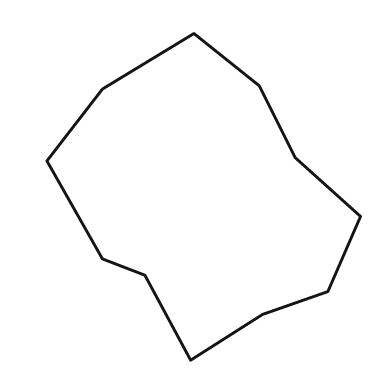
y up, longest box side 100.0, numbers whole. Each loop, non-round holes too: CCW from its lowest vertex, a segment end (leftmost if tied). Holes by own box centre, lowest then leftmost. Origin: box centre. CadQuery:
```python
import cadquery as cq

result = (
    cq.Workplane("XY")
    .moveTo(-4.0, -50.0)
    .lineTo(18.0, -36.0)
    .lineTo(38.0, -29.0)
    .lineTo(48.0, -6.0)
    .lineTo(28.0, 12.0)
    .lineTo(17.0, 34.0)
    .lineTo(-3.0, 50.0)
    .lineTo(-31.0, 33.0)
    .lineTo(-48.0, 11.0)
    .lineTo(-31.0, -19.0)
    .lineTo(-18.0, -24.0)
    .close()
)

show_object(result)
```